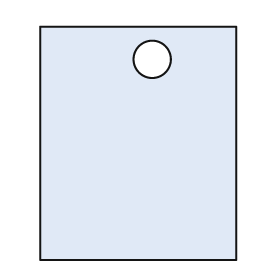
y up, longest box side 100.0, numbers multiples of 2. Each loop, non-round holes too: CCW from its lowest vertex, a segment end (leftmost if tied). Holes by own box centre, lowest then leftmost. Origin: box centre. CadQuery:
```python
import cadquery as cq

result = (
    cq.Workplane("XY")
    .moveTo(-42.0, -50.0)
    .lineTo(42.0, -50.0)
    .lineTo(42.0, 50.0)
    .lineTo(-42.0, 50.0)
    .close()
    .moveTo(6.0, 36.0)
    .circle(8.0)
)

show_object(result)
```